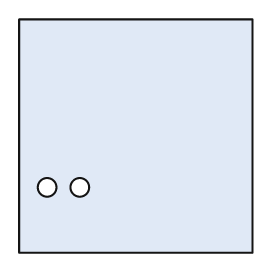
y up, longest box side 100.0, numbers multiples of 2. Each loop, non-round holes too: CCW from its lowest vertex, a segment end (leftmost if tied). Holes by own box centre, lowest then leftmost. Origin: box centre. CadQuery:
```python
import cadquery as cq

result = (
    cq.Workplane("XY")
    .moveTo(-50.0, -50.0)
    .lineTo(50.0, -50.0)
    .lineTo(50.0, 50.0)
    .lineTo(-50.0, 50.0)
    .close()
    .moveTo(-38.0, -22.0)
    .circle(4.0)
    .moveTo(-24.0, -22.0)
    .circle(4.0)
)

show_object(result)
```